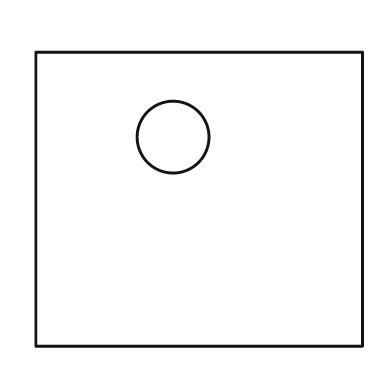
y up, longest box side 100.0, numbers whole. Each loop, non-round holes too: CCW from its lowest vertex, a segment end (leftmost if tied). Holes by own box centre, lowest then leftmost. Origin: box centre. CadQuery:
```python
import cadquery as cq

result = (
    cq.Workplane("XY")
    .moveTo(-50.0, -45.0)
    .lineTo(50.0, -45.0)
    .lineTo(50.0, 45.0)
    .lineTo(-50.0, 45.0)
    .close()
    .moveTo(-8.0, 19.0)
    .circle(11.0)
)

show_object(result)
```